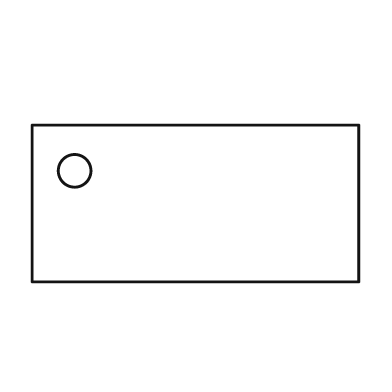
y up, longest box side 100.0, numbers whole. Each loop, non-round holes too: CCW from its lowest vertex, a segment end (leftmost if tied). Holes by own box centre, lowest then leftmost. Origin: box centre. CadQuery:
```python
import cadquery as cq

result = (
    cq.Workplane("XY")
    .moveTo(-50.0, -24.0)
    .lineTo(50.0, -24.0)
    .lineTo(50.0, 24.0)
    .lineTo(-50.0, 24.0)
    .close()
    .moveTo(-37.0, 10.0)
    .circle(5.0)
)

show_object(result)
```